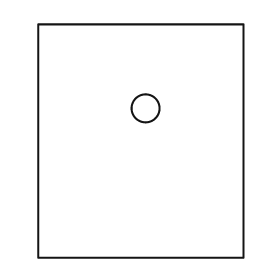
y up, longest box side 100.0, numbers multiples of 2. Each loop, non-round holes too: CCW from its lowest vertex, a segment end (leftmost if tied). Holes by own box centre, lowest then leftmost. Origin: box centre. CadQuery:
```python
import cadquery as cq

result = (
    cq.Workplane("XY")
    .moveTo(-44.0, -50.0)
    .lineTo(44.0, -50.0)
    .lineTo(44.0, 50.0)
    .lineTo(-44.0, 50.0)
    .close()
    .moveTo(2.0, 14.0)
    .circle(6.0)
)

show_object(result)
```